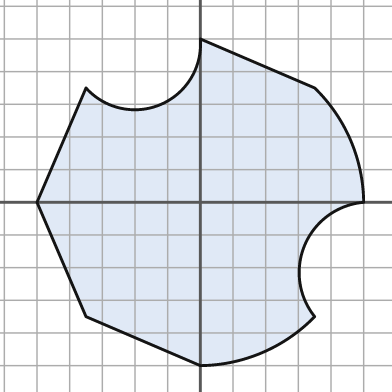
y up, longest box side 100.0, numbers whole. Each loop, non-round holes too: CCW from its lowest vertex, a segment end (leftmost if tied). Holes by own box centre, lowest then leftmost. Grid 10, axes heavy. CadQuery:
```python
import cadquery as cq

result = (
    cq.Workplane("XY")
    .moveTo(0.0, -50.0)
    .threePointArc((19.0, -46.0), (35.0, -35.0))
    .threePointArc((32.0, -13.0), (50.0, 0.0))
    .threePointArc((46.0, 19.0), (35.0, 35.0))
    .lineTo(0.0, 50.0)
    .threePointArc((-12.0, 30.0), (-35.0, 35.0))
    .lineTo(-50.0, 0.0)
    .lineTo(-35.0, -35.0)
    .close()
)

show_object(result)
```